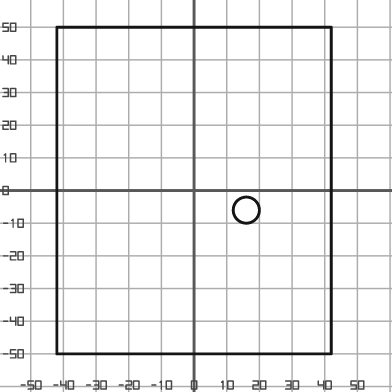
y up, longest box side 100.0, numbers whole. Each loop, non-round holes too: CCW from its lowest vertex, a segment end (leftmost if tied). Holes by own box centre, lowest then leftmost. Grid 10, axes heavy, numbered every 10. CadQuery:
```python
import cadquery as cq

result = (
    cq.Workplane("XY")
    .moveTo(-42.0, -50.0)
    .lineTo(42.0, -50.0)
    .lineTo(42.0, 50.0)
    .lineTo(-42.0, 50.0)
    .close()
    .moveTo(16.0, -6.0)
    .circle(4.0)
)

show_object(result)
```